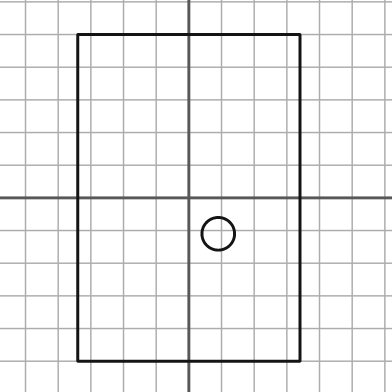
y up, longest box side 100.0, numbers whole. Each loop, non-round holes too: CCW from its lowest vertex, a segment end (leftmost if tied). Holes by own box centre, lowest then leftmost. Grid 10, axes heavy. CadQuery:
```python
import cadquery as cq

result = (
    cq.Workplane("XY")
    .moveTo(-34.0, -50.0)
    .lineTo(34.0, -50.0)
    .lineTo(34.0, 50.0)
    .lineTo(-34.0, 50.0)
    .close()
    .moveTo(9.0, -11.0)
    .circle(5.0)
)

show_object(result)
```